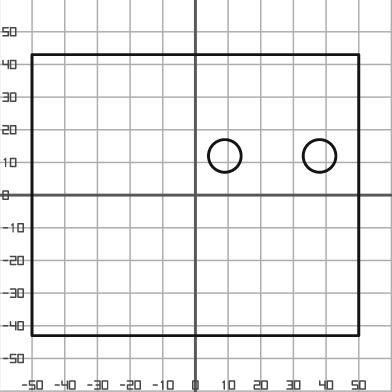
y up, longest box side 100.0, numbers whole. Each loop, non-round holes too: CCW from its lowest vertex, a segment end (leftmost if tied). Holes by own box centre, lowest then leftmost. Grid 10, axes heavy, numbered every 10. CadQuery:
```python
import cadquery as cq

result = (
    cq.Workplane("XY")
    .moveTo(-50.0, -43.0)
    .lineTo(50.0, -43.0)
    .lineTo(50.0, 43.0)
    .lineTo(-50.0, 43.0)
    .close()
    .moveTo(9.0, 12.0)
    .circle(5.0)
    .moveTo(38.0, 12.0)
    .circle(5.0)
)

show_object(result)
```